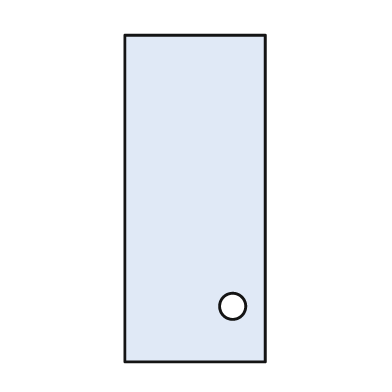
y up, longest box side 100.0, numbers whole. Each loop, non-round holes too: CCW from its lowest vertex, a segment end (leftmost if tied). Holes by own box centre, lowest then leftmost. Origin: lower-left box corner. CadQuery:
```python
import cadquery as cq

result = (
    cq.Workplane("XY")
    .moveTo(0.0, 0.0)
    .lineTo(43.0, 0.0)
    .lineTo(43.0, 100.0)
    .lineTo(0.0, 100.0)
    .close()
    .moveTo(33.0, 17.0)
    .circle(4.0)
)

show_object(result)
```